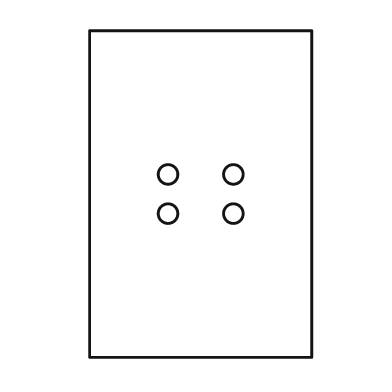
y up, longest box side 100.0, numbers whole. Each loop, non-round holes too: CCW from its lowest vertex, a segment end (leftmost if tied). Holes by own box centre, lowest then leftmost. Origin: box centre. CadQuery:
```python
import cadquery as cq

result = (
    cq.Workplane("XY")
    .moveTo(-34.0, -50.0)
    .lineTo(34.0, -50.0)
    .lineTo(34.0, 50.0)
    .lineTo(-34.0, 50.0)
    .close()
    .moveTo(-10.0, -6.0)
    .circle(3.0)
    .moveTo(10.0, -6.0)
    .circle(3.0)
    .moveTo(-10.0, 6.0)
    .circle(3.0)
    .moveTo(10.0, 6.0)
    .circle(3.0)
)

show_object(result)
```